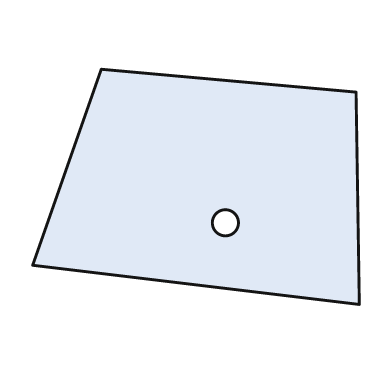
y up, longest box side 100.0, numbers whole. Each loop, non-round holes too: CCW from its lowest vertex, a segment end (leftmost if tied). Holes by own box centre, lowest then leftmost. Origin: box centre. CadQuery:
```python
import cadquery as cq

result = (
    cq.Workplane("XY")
    .moveTo(50.0, -36.0)
    .lineTo(49.0, 29.0)
    .lineTo(-29.0, 36.0)
    .lineTo(-50.0, -24.0)
    .close()
    .moveTo(9.0, -11.0)
    .circle(4.0)
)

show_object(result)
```